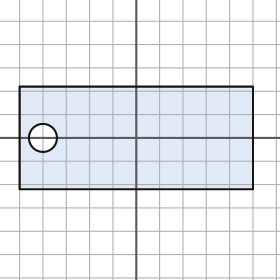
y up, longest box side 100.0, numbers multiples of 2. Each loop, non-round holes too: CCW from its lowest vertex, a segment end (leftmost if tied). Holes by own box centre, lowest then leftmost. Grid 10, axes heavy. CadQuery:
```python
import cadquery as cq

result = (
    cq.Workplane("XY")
    .moveTo(-50.0, -22.0)
    .lineTo(50.0, -22.0)
    .lineTo(50.0, 22.0)
    .lineTo(-50.0, 22.0)
    .close()
    .moveTo(-40.0, 0.0)
    .circle(6.0)
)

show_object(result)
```